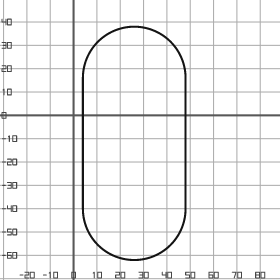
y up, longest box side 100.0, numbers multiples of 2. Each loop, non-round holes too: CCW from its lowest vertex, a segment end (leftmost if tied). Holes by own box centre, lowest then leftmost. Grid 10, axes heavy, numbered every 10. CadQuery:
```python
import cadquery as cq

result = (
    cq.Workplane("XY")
    .moveTo(4.0, -40.0)
    .threePointArc((26.0, -62.0), (48.0, -40.0))
    .lineTo(48.0, 16.0)
    .threePointArc((26.0, 38.0), (4.0, 16.0))
    .close()
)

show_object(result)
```